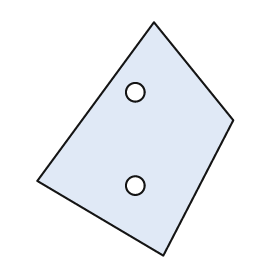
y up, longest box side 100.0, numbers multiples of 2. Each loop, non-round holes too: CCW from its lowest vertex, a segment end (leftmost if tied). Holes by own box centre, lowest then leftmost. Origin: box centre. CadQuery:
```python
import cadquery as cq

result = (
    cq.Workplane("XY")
    .moveTo(12.0, -50.0)
    .lineTo(42.0, 8.0)
    .lineTo(8.0, 50.0)
    .lineTo(-42.0, -18.0)
    .close()
    .moveTo(0.0, -20.0)
    .circle(4.0)
    .moveTo(0.0, 20.0)
    .circle(4.0)
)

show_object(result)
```